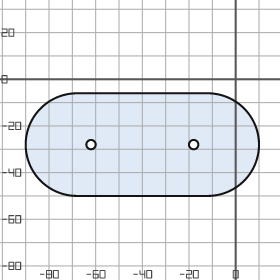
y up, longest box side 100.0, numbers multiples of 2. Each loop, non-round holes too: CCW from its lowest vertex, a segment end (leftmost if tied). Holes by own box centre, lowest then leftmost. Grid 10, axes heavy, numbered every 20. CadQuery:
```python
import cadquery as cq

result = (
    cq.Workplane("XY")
    .moveTo(-68.0, -50.0)
    .lineTo(-12.0, -50.0)
    .threePointArc((10.0, -28.0), (-12.0, -6.0))
    .lineTo(-68.0, -6.0)
    .threePointArc((-90.0, -28.0), (-68.0, -50.0))
    .close()
    .moveTo(-62.0, -28.0)
    .circle(2.0)
    .moveTo(-18.0, -28.0)
    .circle(2.0)
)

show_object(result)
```